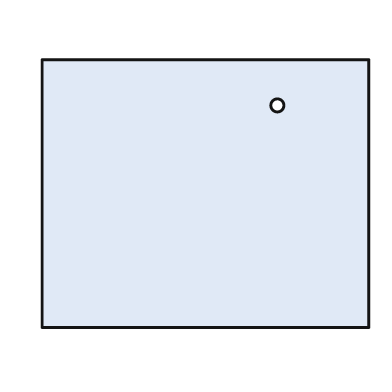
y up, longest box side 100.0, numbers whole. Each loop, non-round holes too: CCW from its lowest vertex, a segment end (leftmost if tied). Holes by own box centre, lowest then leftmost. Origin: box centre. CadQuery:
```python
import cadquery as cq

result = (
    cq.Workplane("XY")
    .moveTo(-50.0, -41.0)
    .lineTo(50.0, -41.0)
    .lineTo(50.0, 41.0)
    .lineTo(-50.0, 41.0)
    .close()
    .moveTo(22.0, 27.0)
    .circle(2.0)
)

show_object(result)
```